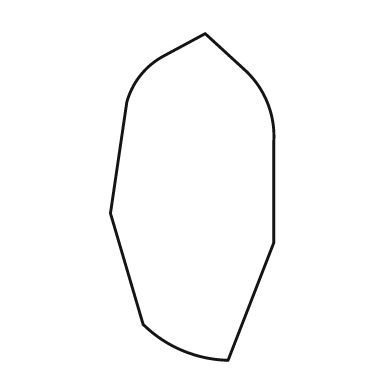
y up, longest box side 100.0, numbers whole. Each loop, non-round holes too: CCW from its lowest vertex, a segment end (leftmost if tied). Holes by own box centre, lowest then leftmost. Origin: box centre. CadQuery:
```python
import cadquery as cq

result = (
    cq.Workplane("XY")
    .moveTo(11.0, -50.0)
    .lineTo(25.0, -14.0)
    .lineTo(25.0, 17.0)
    .threePointArc((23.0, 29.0), (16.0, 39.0))
    .lineTo(4.0, 50.0)
    .lineTo(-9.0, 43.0)
    .threePointArc((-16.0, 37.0), (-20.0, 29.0))
    .lineTo(-25.0, -5.0)
    .lineTo(-15.0, -39.0)
    .threePointArc((-3.0, -47.0), (11.0, -50.0))
    .close()
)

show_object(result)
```